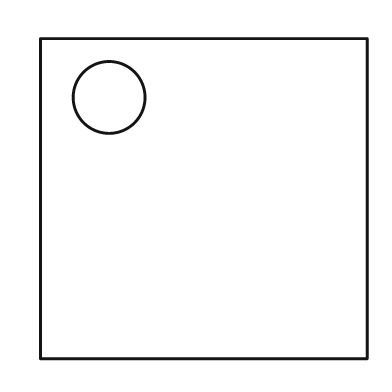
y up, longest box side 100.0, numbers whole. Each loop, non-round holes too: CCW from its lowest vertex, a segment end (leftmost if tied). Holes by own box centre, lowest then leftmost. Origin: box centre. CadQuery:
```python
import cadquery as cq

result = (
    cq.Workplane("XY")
    .moveTo(-50.0, -49.0)
    .lineTo(50.0, -49.0)
    .lineTo(50.0, 49.0)
    .lineTo(-50.0, 49.0)
    .close()
    .moveTo(-29.0, 31.0)
    .circle(11.0)
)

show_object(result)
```